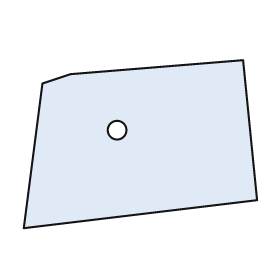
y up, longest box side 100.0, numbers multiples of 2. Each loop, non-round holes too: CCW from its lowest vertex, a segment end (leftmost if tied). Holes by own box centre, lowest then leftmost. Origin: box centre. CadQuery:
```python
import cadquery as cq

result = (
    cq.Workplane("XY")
    .moveTo(-50.0, -36.0)
    .lineTo(50.0, -24.0)
    .lineTo(44.0, 36.0)
    .lineTo(-30.0, 30.0)
    .lineTo(-42.0, 26.0)
    .close()
    .moveTo(-10.0, 6.0)
    .circle(4.0)
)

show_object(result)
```